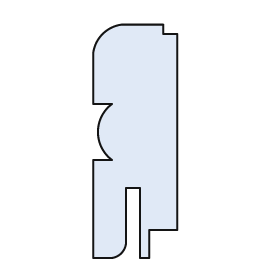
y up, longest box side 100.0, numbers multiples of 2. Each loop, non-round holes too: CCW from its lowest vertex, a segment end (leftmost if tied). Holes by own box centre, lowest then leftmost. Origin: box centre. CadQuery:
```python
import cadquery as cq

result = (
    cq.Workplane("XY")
    .moveTo(-18.0, -50.0)
    .lineTo(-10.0, -50.0)
    .threePointArc((-6.0, -48.0), (-4.0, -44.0))
    .lineTo(-4.0, -20.0)
    .lineTo(2.0, -20.0)
    .lineTo(2.0, -50.0)
    .lineTo(6.0, -50.0)
    .lineTo(6.0, -38.0)
    .lineTo(18.0, -38.0)
    .lineTo(18.0, 46.0)
    .lineTo(12.0, 46.0)
    .lineTo(12.0, 50.0)
    .lineTo(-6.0, 50.0)
    .threePointArc((-14.0, 46.0), (-18.0, 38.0))
    .lineTo(-18.0, 16.0)
    .lineTo(-10.0, 16.0)
    .threePointArc((-16.0, 4.0), (-10.0, -8.0))
    .lineTo(-18.0, -8.0)
    .close()
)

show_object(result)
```